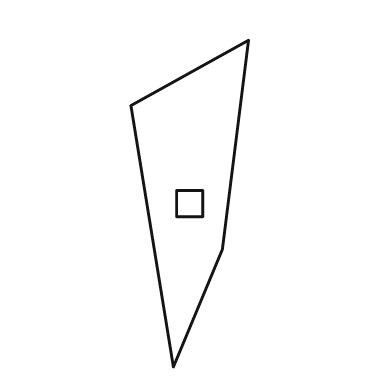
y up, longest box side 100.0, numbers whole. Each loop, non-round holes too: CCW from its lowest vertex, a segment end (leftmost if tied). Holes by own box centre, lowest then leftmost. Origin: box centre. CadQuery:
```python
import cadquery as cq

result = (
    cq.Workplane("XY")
    .moveTo(-5.0, -50.0)
    .lineTo(10.0, -14.0)
    .lineTo(18.0, 50.0)
    .lineTo(-18.0, 30.0)
    .close()
    .moveTo(-4.0, -4.0)
    .lineTo(4.0, -4.0)
    .lineTo(4.0, 4.0)
    .lineTo(-4.0, 4.0)
    .close()
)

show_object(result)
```